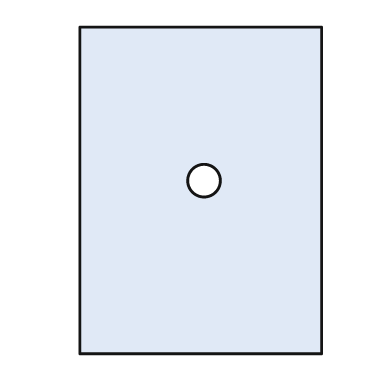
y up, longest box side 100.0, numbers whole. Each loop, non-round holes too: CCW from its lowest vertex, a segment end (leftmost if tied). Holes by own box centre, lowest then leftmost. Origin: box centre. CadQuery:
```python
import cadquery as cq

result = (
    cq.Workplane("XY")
    .moveTo(-37.0, -50.0)
    .lineTo(37.0, -50.0)
    .lineTo(37.0, 50.0)
    .lineTo(-37.0, 50.0)
    .close()
    .moveTo(1.0, 3.0)
    .circle(5.0)
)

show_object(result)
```